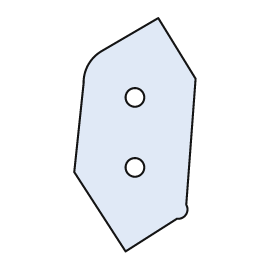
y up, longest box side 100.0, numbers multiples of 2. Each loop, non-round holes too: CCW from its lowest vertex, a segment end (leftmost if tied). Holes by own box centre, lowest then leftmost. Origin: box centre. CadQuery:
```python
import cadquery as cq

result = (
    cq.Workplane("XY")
    .moveTo(-4.0, -50.0)
    .lineTo(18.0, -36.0)
    .threePointArc((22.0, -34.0), (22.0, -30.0))
    .lineTo(26.0, 24.0)
    .lineTo(10.0, 50.0)
    .lineTo(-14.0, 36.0)
    .threePointArc((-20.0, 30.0), (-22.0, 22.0))
    .lineTo(-26.0, -16.0)
    .close()
    .moveTo(0.0, -14.0)
    .circle(4.0)
    .moveTo(0.0, 16.0)
    .circle(4.0)
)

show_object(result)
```